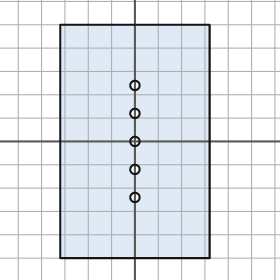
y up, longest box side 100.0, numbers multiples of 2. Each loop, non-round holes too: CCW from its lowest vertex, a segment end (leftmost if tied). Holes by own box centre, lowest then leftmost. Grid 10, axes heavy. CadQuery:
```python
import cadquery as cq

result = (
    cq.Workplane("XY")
    .moveTo(-32.0, -50.0)
    .lineTo(32.0, -50.0)
    .lineTo(32.0, 50.0)
    .lineTo(-32.0, 50.0)
    .close()
    .moveTo(0.0, -24.0)
    .circle(2.0)
    .moveTo(0.0, -12.0)
    .circle(2.0)
    .moveTo(0.0, 0.0)
    .circle(2.0)
    .moveTo(0.0, 12.0)
    .circle(2.0)
    .moveTo(0.0, 24.0)
    .circle(2.0)
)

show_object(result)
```